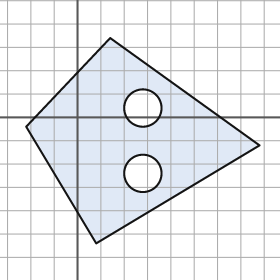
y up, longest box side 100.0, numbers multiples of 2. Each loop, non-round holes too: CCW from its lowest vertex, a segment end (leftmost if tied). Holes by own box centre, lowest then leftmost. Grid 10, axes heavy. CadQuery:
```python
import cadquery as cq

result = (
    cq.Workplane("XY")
    .moveTo(8.0, -54.0)
    .lineTo(78.0, -12.0)
    .lineTo(14.0, 34.0)
    .lineTo(-22.0, -4.0)
    .close()
    .moveTo(28.0, -24.0)
    .circle(8.0)
    .moveTo(28.0, 4.0)
    .circle(8.0)
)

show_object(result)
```